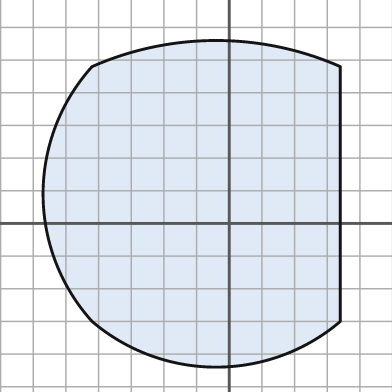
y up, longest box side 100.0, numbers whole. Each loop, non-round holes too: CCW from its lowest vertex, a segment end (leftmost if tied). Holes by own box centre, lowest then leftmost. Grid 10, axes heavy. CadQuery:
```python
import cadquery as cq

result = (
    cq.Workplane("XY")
    .moveTo(-42.0, -30.0)
    .threePointArc((-4.0, -44.0), (34.0, -30.0))
    .lineTo(34.0, 48.0)
    .threePointArc((-4.0, 56.0), (-42.0, 48.0))
    .threePointArc((-57.0, 9.0), (-42.0, -30.0))
    .close()
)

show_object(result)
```